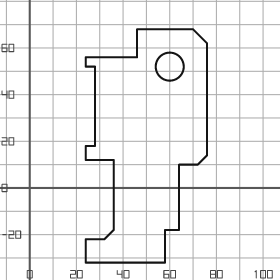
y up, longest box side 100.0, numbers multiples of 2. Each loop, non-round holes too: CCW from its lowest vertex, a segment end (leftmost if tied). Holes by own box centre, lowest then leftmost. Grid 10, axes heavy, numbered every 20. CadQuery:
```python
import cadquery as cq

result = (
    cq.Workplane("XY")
    .moveTo(24.0, -32.0)
    .lineTo(58.0, -32.0)
    .lineTo(58.0, -18.0)
    .lineTo(64.0, -18.0)
    .lineTo(64.0, 10.0)
    .lineTo(72.0, 10.0)
    .lineTo(76.0, 14.0)
    .lineTo(76.0, 62.0)
    .lineTo(70.0, 68.0)
    .lineTo(46.0, 68.0)
    .lineTo(46.0, 56.0)
    .lineTo(24.0, 56.0)
    .lineTo(24.0, 52.0)
    .lineTo(28.0, 52.0)
    .lineTo(28.0, 18.0)
    .lineTo(24.0, 18.0)
    .lineTo(24.0, 12.0)
    .lineTo(36.0, 12.0)
    .lineTo(36.0, -18.0)
    .lineTo(32.0, -22.0)
    .lineTo(24.0, -22.0)
    .close()
    .moveTo(60.0, 52.0)
    .circle(6.0)
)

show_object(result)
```